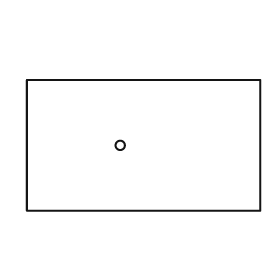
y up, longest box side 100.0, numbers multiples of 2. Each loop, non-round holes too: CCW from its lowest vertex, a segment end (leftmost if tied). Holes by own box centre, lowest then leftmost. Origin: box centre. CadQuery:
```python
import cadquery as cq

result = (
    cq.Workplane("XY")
    .moveTo(-50.0, -28.0)
    .lineTo(50.0, -28.0)
    .lineTo(50.0, 28.0)
    .lineTo(-50.0, 28.0)
    .close()
    .moveTo(-10.0, 0.0)
    .circle(2.0)
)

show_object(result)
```